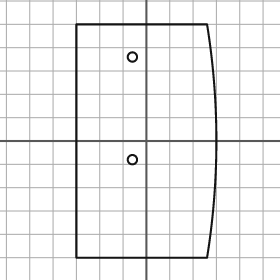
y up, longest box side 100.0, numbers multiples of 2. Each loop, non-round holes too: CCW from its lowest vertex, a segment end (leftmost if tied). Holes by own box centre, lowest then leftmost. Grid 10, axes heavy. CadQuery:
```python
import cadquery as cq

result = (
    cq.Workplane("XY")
    .moveTo(-30.0, -50.0)
    .lineTo(26.0, -50.0)
    .threePointArc((30.0, 0.0), (26.0, 50.0))
    .lineTo(-30.0, 50.0)
    .close()
    .moveTo(-6.0, -8.0)
    .circle(2.0)
    .moveTo(-6.0, 36.0)
    .circle(2.0)
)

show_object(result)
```